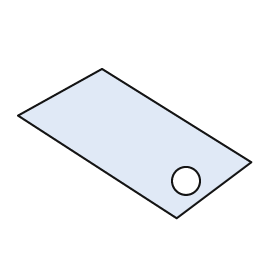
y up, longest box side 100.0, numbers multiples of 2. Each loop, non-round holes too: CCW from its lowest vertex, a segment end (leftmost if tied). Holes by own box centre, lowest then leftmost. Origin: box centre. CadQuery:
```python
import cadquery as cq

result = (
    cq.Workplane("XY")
    .moveTo(18.0, -32.0)
    .lineTo(50.0, -8.0)
    .lineTo(-14.0, 32.0)
    .lineTo(-50.0, 12.0)
    .close()
    .moveTo(22.0, -16.0)
    .circle(6.0)
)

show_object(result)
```